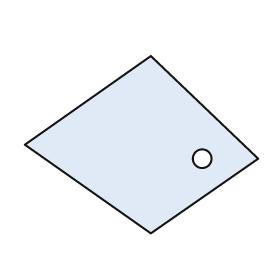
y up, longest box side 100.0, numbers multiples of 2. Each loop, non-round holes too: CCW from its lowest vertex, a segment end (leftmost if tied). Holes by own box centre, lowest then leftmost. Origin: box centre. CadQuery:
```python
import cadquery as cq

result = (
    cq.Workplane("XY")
    .moveTo(4.0, -38.0)
    .lineTo(50.0, -6.0)
    .lineTo(4.0, 38.0)
    .lineTo(-50.0, 0.0)
    .close()
    .moveTo(26.0, -6.0)
    .circle(4.0)
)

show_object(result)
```